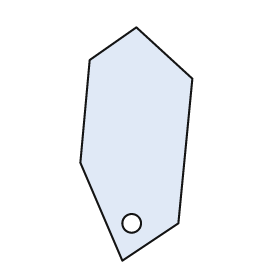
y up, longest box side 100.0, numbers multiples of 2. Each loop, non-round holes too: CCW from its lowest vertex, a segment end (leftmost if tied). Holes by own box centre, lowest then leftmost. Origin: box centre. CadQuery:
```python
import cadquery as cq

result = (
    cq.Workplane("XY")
    .moveTo(-6.0, -50.0)
    .lineTo(18.0, -34.0)
    .lineTo(24.0, 28.0)
    .lineTo(0.0, 50.0)
    .lineTo(-20.0, 36.0)
    .lineTo(-24.0, -8.0)
    .close()
    .moveTo(-2.0, -34.0)
    .circle(4.0)
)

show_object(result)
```